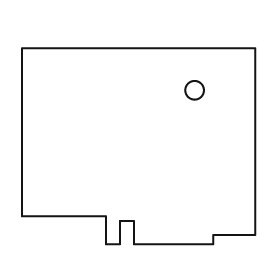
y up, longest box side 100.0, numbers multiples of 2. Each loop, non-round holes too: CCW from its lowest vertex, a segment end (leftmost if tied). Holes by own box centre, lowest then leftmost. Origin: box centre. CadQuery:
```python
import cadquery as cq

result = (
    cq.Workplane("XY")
    .moveTo(-14.0, -42.0)
    .lineTo(-8.0, -42.0)
    .lineTo(-8.0, -32.0)
    .lineTo(-2.0, -32.0)
    .lineTo(-2.0, -42.0)
    .lineTo(32.0, -42.0)
    .lineTo(32.0, -38.0)
    .lineTo(50.0, -38.0)
    .lineTo(50.0, 42.0)
    .lineTo(-50.0, 42.0)
    .lineTo(-50.0, -30.0)
    .lineTo(-14.0, -30.0)
    .close()
    .moveTo(24.0, 24.0)
    .circle(4.0)
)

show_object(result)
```